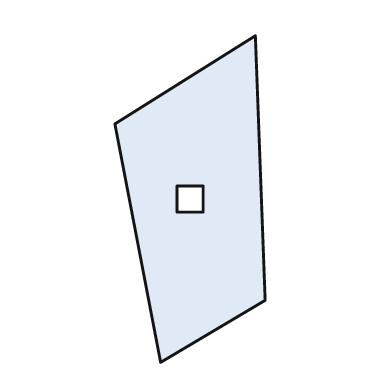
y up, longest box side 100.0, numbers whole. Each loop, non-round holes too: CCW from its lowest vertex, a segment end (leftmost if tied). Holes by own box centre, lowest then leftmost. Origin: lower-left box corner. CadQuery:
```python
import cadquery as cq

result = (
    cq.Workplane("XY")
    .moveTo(14.0, 0.0)
    .lineTo(46.0, 19.0)
    .lineTo(43.0, 100.0)
    .lineTo(0.0, 73.0)
    .close()
    .moveTo(19.0, 46.0)
    .lineTo(27.0, 46.0)
    .lineTo(27.0, 54.0)
    .lineTo(19.0, 54.0)
    .close()
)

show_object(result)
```